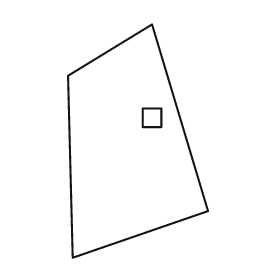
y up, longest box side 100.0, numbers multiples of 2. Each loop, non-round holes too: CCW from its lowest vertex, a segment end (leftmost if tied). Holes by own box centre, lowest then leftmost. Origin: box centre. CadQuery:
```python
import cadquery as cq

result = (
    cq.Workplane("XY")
    .moveTo(-28.0, -50.0)
    .lineTo(30.0, -30.0)
    .lineTo(6.0, 50.0)
    .lineTo(-30.0, 28.0)
    .close()
    .moveTo(2.0, 6.0)
    .lineTo(10.0, 6.0)
    .lineTo(10.0, 14.0)
    .lineTo(2.0, 14.0)
    .close()
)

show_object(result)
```